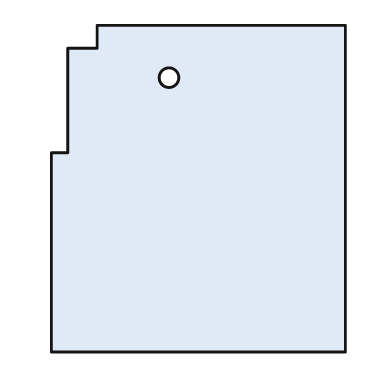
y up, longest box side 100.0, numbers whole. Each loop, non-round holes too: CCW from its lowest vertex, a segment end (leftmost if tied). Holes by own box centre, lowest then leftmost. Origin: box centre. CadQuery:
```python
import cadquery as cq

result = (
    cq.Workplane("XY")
    .moveTo(-45.0, -50.0)
    .lineTo(45.0, -50.0)
    .lineTo(45.0, 50.0)
    .lineTo(-31.0, 50.0)
    .lineTo(-31.0, 43.0)
    .lineTo(-40.0, 43.0)
    .lineTo(-40.0, 11.0)
    .lineTo(-45.0, 11.0)
    .close()
    .moveTo(-9.0, 34.0)
    .circle(3.0)
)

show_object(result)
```